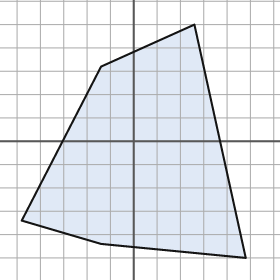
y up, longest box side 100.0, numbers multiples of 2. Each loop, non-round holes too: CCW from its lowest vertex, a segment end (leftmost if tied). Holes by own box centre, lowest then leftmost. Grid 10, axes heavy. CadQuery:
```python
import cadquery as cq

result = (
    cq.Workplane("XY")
    .moveTo(48.0, -50.0)
    .lineTo(26.0, 50.0)
    .lineTo(-14.0, 32.0)
    .lineTo(-48.0, -34.0)
    .lineTo(-14.0, -44.0)
    .close()
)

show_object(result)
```